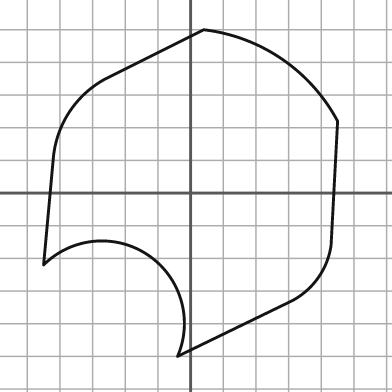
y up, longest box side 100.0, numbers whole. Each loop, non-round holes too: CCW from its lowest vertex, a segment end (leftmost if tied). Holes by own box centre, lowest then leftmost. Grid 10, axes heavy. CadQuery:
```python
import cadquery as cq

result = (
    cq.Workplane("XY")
    .moveTo(-4.0, -50.0)
    .lineTo(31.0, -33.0)
    .threePointArc((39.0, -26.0), (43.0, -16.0))
    .lineTo(45.0, 22.0)
    .threePointArc((28.0, 41.0), (4.0, 50.0))
    .lineTo(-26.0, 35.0)
    .threePointArc((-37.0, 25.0), (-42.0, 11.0))
    .lineTo(-45.0, -22.0)
    .threePointArc((-13.0, -19.0), (-4.0, -50.0))
    .close()
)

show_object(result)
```